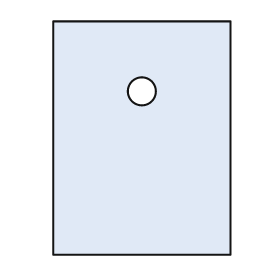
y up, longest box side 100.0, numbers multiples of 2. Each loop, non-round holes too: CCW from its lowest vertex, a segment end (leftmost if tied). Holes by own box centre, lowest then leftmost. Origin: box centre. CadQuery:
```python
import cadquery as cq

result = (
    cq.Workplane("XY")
    .moveTo(-38.0, -50.0)
    .lineTo(38.0, -50.0)
    .lineTo(38.0, 50.0)
    .lineTo(-38.0, 50.0)
    .close()
    .moveTo(0.0, 20.0)
    .circle(6.0)
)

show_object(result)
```